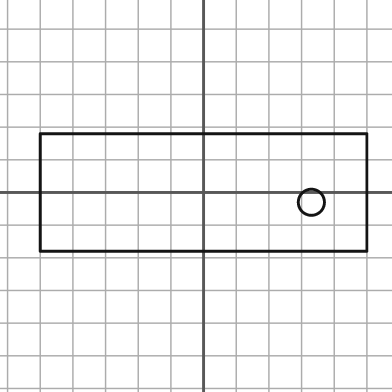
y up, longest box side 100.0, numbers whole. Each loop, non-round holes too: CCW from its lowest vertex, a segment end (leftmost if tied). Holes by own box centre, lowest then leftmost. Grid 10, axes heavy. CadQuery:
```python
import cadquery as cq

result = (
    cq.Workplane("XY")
    .moveTo(-50.0, -18.0)
    .lineTo(50.0, -18.0)
    .lineTo(50.0, 18.0)
    .lineTo(-50.0, 18.0)
    .close()
    .moveTo(33.0, -3.0)
    .circle(4.0)
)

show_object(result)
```